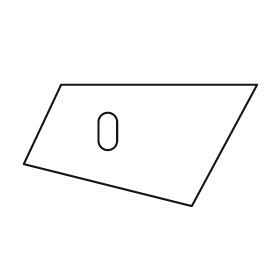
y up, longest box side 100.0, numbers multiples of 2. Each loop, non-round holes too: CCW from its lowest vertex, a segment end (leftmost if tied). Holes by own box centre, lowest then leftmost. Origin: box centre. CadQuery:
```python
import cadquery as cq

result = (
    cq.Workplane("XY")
    .moveTo(22.0, -26.0)
    .lineTo(50.0, 26.0)
    .lineTo(-34.0, 26.0)
    .lineTo(-50.0, -8.0)
    .close()
    .moveTo(-18.0, 2.0)
    .threePointArc((-14.0, -2.0), (-10.0, 2.0))
    .lineTo(-10.0, 10.0)
    .threePointArc((-14.0, 14.0), (-18.0, 10.0))
    .close()
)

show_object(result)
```